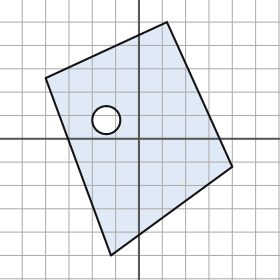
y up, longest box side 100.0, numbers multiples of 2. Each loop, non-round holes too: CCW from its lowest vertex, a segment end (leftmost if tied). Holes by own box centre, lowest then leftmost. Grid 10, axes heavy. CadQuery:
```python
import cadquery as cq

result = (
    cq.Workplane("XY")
    .moveTo(-12.0, -50.0)
    .lineTo(40.0, -12.0)
    .lineTo(12.0, 50.0)
    .lineTo(-40.0, 26.0)
    .close()
    .moveTo(-14.0, 8.0)
    .circle(6.0)
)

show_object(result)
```